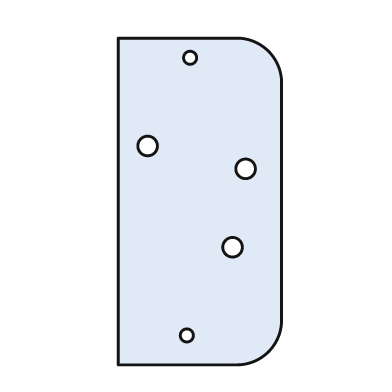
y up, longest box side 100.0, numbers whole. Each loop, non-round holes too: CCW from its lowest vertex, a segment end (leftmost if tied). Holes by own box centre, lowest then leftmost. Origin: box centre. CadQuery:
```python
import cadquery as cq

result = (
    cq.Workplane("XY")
    .moveTo(-25.0, -50.0)
    .lineTo(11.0, -50.0)
    .threePointArc((21.0, -46.0), (25.0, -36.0))
    .lineTo(25.0, 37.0)
    .threePointArc((21.0, 46.0), (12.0, 50.0))
    .lineTo(-25.0, 50.0)
    .close()
    .moveTo(-4.0, -41.0)
    .circle(2.0)
    .moveTo(10.0, -14.0)
    .circle(3.0)
    .moveTo(14.0, 10.0)
    .circle(3.0)
    .moveTo(-16.0, 17.0)
    .circle(3.0)
    .moveTo(-3.0, 44.0)
    .circle(2.0)
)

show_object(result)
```